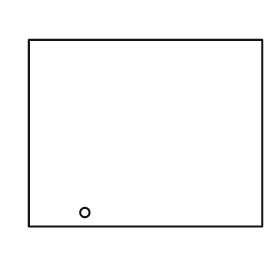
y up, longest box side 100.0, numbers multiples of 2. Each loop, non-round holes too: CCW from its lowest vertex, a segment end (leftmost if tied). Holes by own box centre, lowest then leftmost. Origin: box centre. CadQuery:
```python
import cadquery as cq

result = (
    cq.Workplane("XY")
    .moveTo(-50.0, -40.0)
    .lineTo(50.0, -40.0)
    .lineTo(50.0, 40.0)
    .lineTo(-50.0, 40.0)
    .close()
    .moveTo(-26.0, -34.0)
    .circle(2.0)
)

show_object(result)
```